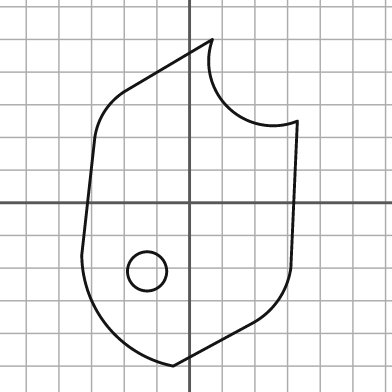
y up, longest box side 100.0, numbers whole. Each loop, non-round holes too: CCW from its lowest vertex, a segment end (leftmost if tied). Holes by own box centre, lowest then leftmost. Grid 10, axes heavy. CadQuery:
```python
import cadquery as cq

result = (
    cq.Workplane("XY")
    .moveTo(-5.0, -50.0)
    .lineTo(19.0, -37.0)
    .threePointArc((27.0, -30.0), (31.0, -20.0))
    .lineTo(33.0, 25.0)
    .threePointArc((12.0, 29.0), (7.0, 50.0))
    .lineTo(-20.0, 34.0)
    .threePointArc((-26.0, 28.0), (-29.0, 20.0))
    .lineTo(-33.0, -16.0)
    .threePointArc((-25.0, -38.0), (-5.0, -50.0))
    .close()
    .moveTo(-13.0, -21.0)
    .circle(6.0)
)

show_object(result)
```